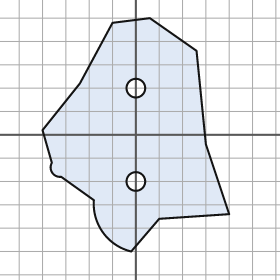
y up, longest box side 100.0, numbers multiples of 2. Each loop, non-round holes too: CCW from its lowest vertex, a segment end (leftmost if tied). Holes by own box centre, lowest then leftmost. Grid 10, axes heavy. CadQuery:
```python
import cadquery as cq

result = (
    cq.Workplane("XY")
    .moveTo(-2.0, -50.0)
    .lineTo(10.0, -36.0)
    .lineTo(40.0, -34.0)
    .lineTo(30.0, -4.0)
    .lineTo(26.0, 36.0)
    .lineTo(6.0, 50.0)
    .lineTo(-10.0, 48.0)
    .lineTo(-24.0, 22.0)
    .lineTo(-40.0, 2.0)
    .lineTo(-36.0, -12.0)
    .threePointArc((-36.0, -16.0), (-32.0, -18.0))
    .lineTo(-18.0, -28.0)
    .threePointArc((-14.0, -42.0), (-2.0, -50.0))
    .close()
    .moveTo(0.0, -20.0)
    .circle(4.0)
    .moveTo(0.0, 20.0)
    .circle(4.0)
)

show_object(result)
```